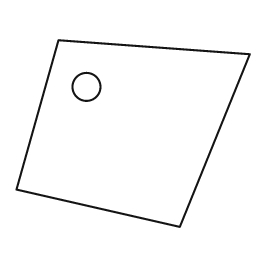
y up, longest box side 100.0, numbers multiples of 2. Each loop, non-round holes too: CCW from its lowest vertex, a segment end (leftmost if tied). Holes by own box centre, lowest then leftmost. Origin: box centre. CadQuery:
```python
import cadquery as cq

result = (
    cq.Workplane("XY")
    .moveTo(20.0, -40.0)
    .lineTo(50.0, 34.0)
    .lineTo(-32.0, 40.0)
    .lineTo(-50.0, -24.0)
    .close()
    .moveTo(-20.0, 20.0)
    .circle(6.0)
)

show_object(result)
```